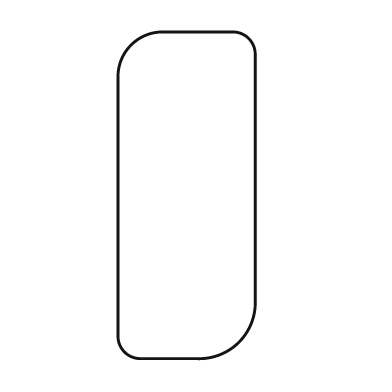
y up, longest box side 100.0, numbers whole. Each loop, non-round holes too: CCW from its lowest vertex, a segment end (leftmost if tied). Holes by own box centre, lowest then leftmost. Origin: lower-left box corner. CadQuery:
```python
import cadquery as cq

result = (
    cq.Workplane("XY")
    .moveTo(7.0, 0.0)
    .lineTo(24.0, 0.0)
    .threePointArc((37.0, 5.0), (42.0, 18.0))
    .lineTo(42.0, 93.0)
    .threePointArc((40.0, 98.0), (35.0, 100.0))
    .lineTo(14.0, 100.0)
    .threePointArc((4.0, 96.0), (0.0, 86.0))
    .lineTo(0.0, 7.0)
    .threePointArc((2.0, 2.0), (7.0, 0.0))
    .close()
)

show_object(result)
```